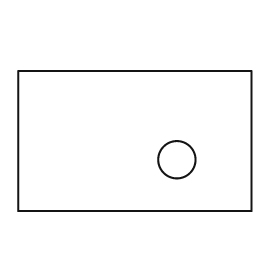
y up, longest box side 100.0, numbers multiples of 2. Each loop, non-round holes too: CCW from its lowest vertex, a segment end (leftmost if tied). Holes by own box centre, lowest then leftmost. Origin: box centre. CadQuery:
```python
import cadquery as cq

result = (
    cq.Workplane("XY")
    .moveTo(-50.0, -30.0)
    .lineTo(50.0, -30.0)
    .lineTo(50.0, 30.0)
    .lineTo(-50.0, 30.0)
    .close()
    .moveTo(18.0, -8.0)
    .circle(8.0)
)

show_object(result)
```